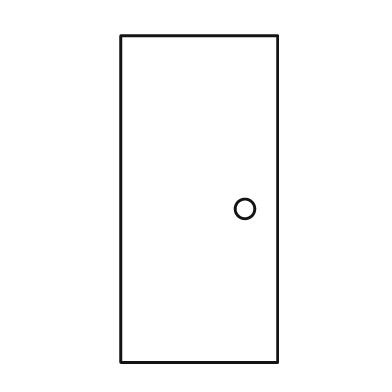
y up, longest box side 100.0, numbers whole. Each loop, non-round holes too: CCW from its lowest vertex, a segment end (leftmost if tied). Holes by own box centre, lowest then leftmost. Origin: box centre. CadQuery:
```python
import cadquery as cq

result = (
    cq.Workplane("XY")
    .moveTo(-24.0, -50.0)
    .lineTo(24.0, -50.0)
    .lineTo(24.0, 50.0)
    .lineTo(-24.0, 50.0)
    .close()
    .moveTo(14.0, -3.0)
    .circle(3.0)
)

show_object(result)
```